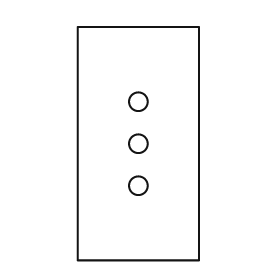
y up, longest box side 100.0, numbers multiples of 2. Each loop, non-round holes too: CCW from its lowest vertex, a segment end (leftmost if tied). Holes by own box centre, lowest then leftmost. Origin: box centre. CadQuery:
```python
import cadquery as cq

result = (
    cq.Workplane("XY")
    .moveTo(-26.0, -50.0)
    .lineTo(26.0, -50.0)
    .lineTo(26.0, 50.0)
    .lineTo(-26.0, 50.0)
    .close()
    .moveTo(0.0, -18.0)
    .circle(4.0)
    .moveTo(0.0, 0.0)
    .circle(4.0)
    .moveTo(0.0, 18.0)
    .circle(4.0)
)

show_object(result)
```